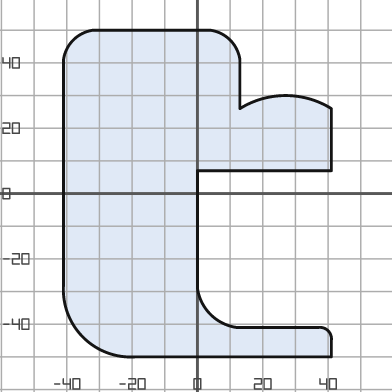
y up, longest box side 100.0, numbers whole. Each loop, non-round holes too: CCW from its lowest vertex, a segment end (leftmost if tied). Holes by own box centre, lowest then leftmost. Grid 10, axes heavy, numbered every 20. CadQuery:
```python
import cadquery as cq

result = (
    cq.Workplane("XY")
    .moveTo(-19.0, -50.0)
    .lineTo(41.0, -50.0)
    .lineTo(41.0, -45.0)
    .threePointArc((40.0, -42.0), (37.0, -41.0))
    .lineTo(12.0, -41.0)
    .threePointArc((4.0, -37.0), (0.0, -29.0))
    .lineTo(0.0, 7.0)
    .lineTo(41.0, 7.0)
    .lineTo(41.0, 26.0)
    .threePointArc((27.0, 30.0), (13.0, 26.0))
    .lineTo(13.0, 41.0)
    .threePointArc((10.0, 47.0), (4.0, 50.0))
    .lineTo(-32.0, 50.0)
    .threePointArc((-38.0, 47.0), (-41.0, 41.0))
    .lineTo(-41.0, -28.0)
    .threePointArc((-35.0, -44.0), (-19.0, -50.0))
    .close()
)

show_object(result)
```